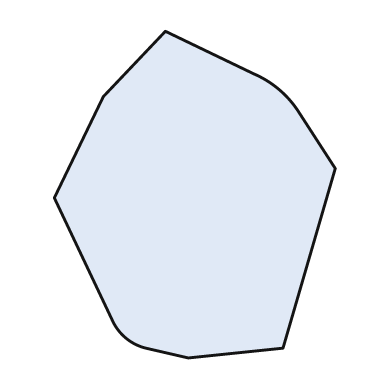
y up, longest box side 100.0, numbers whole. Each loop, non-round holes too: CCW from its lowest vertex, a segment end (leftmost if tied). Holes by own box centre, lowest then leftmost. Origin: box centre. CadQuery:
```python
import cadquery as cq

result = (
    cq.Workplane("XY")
    .moveTo(-2.0, -50.0)
    .lineTo(27.0, -47.0)
    .lineTo(43.0, 8.0)
    .lineTo(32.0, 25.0)
    .threePointArc((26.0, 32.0), (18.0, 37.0))
    .lineTo(-9.0, 50.0)
    .lineTo(-28.0, 30.0)
    .lineTo(-43.0, -1.0)
    .lineTo(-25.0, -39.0)
    .threePointArc((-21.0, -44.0), (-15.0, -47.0))
    .close()
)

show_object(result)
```